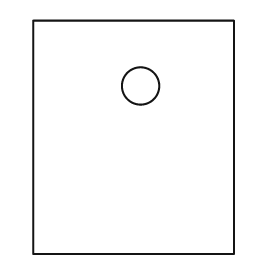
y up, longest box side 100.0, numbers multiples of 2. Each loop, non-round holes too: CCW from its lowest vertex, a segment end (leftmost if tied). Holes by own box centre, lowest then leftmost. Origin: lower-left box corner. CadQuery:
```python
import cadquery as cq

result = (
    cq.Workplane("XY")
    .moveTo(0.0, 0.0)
    .lineTo(86.0, 0.0)
    .lineTo(86.0, 100.0)
    .lineTo(0.0, 100.0)
    .close()
    .moveTo(46.0, 72.0)
    .circle(8.0)
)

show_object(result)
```